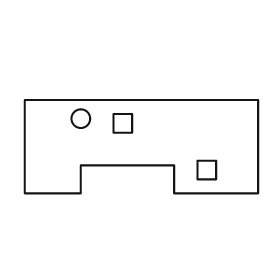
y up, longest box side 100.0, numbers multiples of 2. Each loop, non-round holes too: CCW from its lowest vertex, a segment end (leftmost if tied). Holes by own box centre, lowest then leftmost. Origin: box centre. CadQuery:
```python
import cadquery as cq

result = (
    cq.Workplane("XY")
    .moveTo(-50.0, -20.0)
    .lineTo(-26.0, -20.0)
    .lineTo(-26.0, -8.0)
    .lineTo(14.0, -8.0)
    .lineTo(14.0, -20.0)
    .lineTo(50.0, -20.0)
    .lineTo(50.0, 20.0)
    .lineTo(-50.0, 20.0)
    .close()
    .moveTo(24.0, -14.0)
    .lineTo(32.0, -14.0)
    .lineTo(32.0, -6.0)
    .lineTo(24.0, -6.0)
    .close()
    .moveTo(-12.0, 6.0)
    .lineTo(-4.0, 6.0)
    .lineTo(-4.0, 14.0)
    .lineTo(-12.0, 14.0)
    .close()
    .moveTo(-26.0, 12.0)
    .circle(4.0)
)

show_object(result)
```